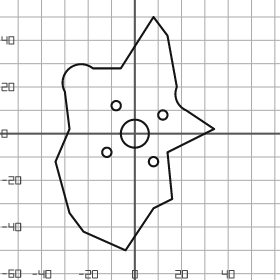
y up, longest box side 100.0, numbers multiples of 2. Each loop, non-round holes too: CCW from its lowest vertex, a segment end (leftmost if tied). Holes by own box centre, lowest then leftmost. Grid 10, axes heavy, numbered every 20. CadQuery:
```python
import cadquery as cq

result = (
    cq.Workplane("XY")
    .moveTo(-4.0, -50.0)
    .lineTo(8.0, -32.0)
    .lineTo(16.0, -28.0)
    .lineTo(14.0, -8.0)
    .lineTo(34.0, 2.0)
    .lineTo(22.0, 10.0)
    .threePointArc((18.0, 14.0), (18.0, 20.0))
    .lineTo(14.0, 42.0)
    .lineTo(8.0, 50.0)
    .lineTo(-6.0, 28.0)
    .lineTo(-18.0, 28.0)
    .threePointArc((-28.0, 28.0), (-30.0, 18.0))
    .lineTo(-28.0, 2.0)
    .lineTo(-34.0, -12.0)
    .lineTo(-28.0, -34.0)
    .lineTo(-22.0, -42.0)
    .close()
    .moveTo(8.0, -12.0)
    .circle(2.0)
    .moveTo(-12.0, -8.0)
    .circle(2.0)
    .moveTo(0.0, 0.0)
    .circle(6.0)
    .moveTo(12.0, 8.0)
    .circle(2.0)
    .moveTo(-8.0, 12.0)
    .circle(2.0)
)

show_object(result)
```